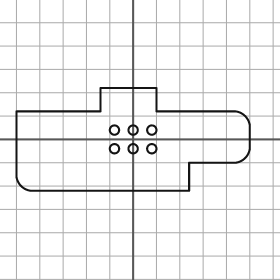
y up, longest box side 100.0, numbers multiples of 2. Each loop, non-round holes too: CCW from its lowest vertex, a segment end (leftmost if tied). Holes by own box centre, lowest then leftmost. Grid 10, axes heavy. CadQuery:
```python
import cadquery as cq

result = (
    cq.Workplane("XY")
    .moveTo(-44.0, -22.0)
    .lineTo(24.0, -22.0)
    .lineTo(24.0, -10.0)
    .lineTo(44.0, -10.0)
    .threePointArc((48.0, -8.0), (50.0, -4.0))
    .lineTo(50.0, 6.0)
    .threePointArc((48.0, 10.0), (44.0, 12.0))
    .lineTo(10.0, 12.0)
    .lineTo(10.0, 22.0)
    .lineTo(-14.0, 22.0)
    .lineTo(-14.0, 12.0)
    .lineTo(-50.0, 12.0)
    .lineTo(-50.0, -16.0)
    .threePointArc((-48.0, -20.0), (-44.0, -22.0))
    .close()
    .moveTo(-8.0, -4.0)
    .circle(2.0)
    .moveTo(0.0, -4.0)
    .circle(2.0)
    .moveTo(8.0, -4.0)
    .circle(2.0)
    .moveTo(-8.0, 4.0)
    .circle(2.0)
    .moveTo(0.0, 4.0)
    .circle(2.0)
    .moveTo(8.0, 4.0)
    .circle(2.0)
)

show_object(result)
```